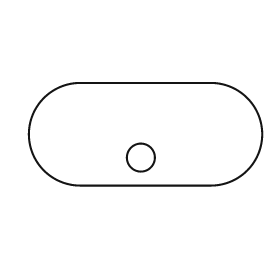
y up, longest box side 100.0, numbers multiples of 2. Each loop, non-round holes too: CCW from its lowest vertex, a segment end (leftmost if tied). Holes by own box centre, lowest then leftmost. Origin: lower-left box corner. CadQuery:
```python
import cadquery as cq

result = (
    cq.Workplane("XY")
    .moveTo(22.0, 0.0)
    .lineTo(78.0, 0.0)
    .threePointArc((100.0, 22.0), (78.0, 44.0))
    .lineTo(22.0, 44.0)
    .threePointArc((0.0, 22.0), (22.0, 0.0))
    .close()
    .moveTo(48.0, 12.0)
    .circle(6.0)
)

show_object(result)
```